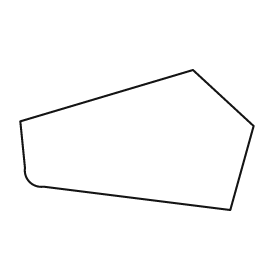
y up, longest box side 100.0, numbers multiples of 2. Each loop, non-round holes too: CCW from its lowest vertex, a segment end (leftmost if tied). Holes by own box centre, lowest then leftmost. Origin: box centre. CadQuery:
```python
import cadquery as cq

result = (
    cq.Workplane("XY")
    .moveTo(40.0, -30.0)
    .lineTo(50.0, 6.0)
    .lineTo(24.0, 30.0)
    .lineTo(-50.0, 8.0)
    .lineTo(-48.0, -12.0)
    .threePointArc((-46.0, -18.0), (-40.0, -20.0))
    .close()
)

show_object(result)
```